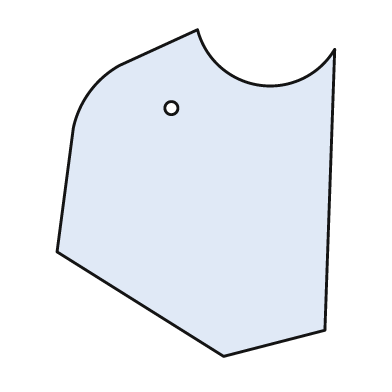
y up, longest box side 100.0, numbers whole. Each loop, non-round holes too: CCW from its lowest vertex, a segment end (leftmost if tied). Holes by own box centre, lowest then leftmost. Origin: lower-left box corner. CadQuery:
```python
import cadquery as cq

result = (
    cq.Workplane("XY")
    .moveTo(51.0, 0.0)
    .lineTo(82.0, 8.0)
    .lineTo(85.0, 94.0)
    .threePointArc((62.0, 83.0), (43.0, 100.0))
    .lineTo(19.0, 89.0)
    .threePointArc((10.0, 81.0), (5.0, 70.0))
    .lineTo(0.0, 32.0)
    .close()
    .moveTo(35.0, 76.0)
    .circle(2.0)
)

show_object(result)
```